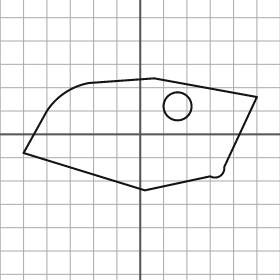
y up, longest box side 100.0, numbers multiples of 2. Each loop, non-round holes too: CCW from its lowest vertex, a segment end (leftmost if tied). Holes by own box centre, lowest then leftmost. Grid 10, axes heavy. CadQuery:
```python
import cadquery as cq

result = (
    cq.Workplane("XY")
    .moveTo(2.0, -24.0)
    .lineTo(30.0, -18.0)
    .threePointArc((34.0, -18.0), (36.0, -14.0))
    .lineTo(50.0, 16.0)
    .lineTo(6.0, 24.0)
    .lineTo(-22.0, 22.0)
    .threePointArc((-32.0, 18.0), (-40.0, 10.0))
    .lineTo(-50.0, -8.0)
    .close()
    .moveTo(16.0, 12.0)
    .circle(6.0)
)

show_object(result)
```